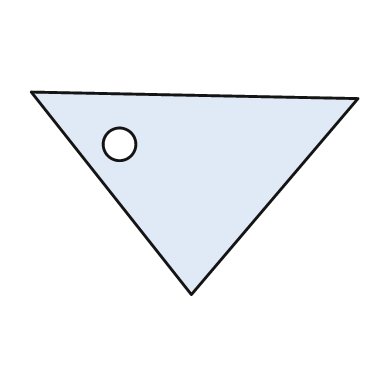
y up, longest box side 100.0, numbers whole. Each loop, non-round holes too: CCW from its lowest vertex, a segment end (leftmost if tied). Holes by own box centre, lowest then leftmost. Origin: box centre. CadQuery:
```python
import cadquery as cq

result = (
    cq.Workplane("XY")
    .moveTo(-1.0, -31.0)
    .lineTo(50.0, 29.0)
    .lineTo(-50.0, 31.0)
    .close()
    .moveTo(-23.0, 15.0)
    .circle(5.0)
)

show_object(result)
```